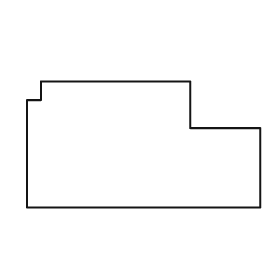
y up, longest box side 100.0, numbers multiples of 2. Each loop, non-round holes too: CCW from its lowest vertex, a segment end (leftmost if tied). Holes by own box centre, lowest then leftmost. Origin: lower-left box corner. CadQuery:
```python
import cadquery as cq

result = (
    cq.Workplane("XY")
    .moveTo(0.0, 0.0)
    .lineTo(100.0, 0.0)
    .lineTo(100.0, 34.0)
    .lineTo(70.0, 34.0)
    .lineTo(70.0, 54.0)
    .lineTo(6.0, 54.0)
    .lineTo(6.0, 46.0)
    .lineTo(0.0, 46.0)
    .close()
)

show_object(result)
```